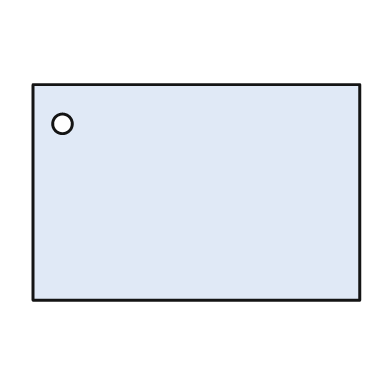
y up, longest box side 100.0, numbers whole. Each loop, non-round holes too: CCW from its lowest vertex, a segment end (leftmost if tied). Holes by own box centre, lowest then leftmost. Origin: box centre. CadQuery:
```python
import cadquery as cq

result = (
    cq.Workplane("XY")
    .moveTo(-50.0, -33.0)
    .lineTo(50.0, -33.0)
    .lineTo(50.0, 33.0)
    .lineTo(-50.0, 33.0)
    .close()
    .moveTo(-41.0, 21.0)
    .circle(3.0)
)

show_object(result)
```